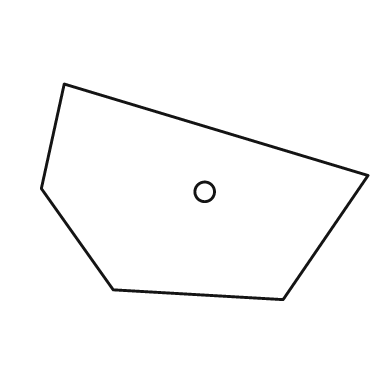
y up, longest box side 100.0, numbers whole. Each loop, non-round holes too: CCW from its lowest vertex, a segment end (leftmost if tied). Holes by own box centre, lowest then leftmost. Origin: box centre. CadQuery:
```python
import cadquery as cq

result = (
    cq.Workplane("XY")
    .moveTo(24.0, -33.0)
    .lineTo(50.0, 5.0)
    .lineTo(-43.0, 33.0)
    .lineTo(-50.0, 1.0)
    .lineTo(-28.0, -30.0)
    .close()
    .moveTo(0.0, 0.0)
    .circle(3.0)
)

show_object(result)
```